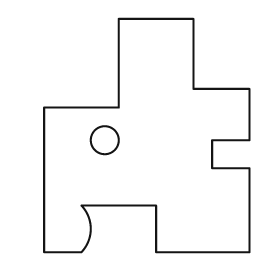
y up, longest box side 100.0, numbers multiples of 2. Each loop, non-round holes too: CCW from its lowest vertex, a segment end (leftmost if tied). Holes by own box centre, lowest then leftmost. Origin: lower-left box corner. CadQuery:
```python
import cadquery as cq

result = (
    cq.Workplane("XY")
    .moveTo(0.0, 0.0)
    .lineTo(16.0, 0.0)
    .threePointArc((20.0, 10.0), (16.0, 20.0))
    .lineTo(48.0, 20.0)
    .lineTo(48.0, 0.0)
    .lineTo(88.0, 0.0)
    .lineTo(88.0, 36.0)
    .lineTo(72.0, 36.0)
    .lineTo(72.0, 48.0)
    .lineTo(88.0, 48.0)
    .lineTo(88.0, 70.0)
    .lineTo(64.0, 70.0)
    .lineTo(64.0, 100.0)
    .lineTo(32.0, 100.0)
    .lineTo(32.0, 62.0)
    .lineTo(0.0, 62.0)
    .close()
    .moveTo(26.0, 48.0)
    .circle(6.0)
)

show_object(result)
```